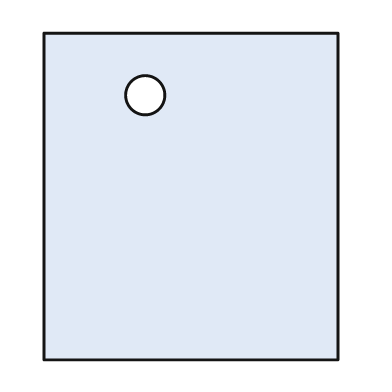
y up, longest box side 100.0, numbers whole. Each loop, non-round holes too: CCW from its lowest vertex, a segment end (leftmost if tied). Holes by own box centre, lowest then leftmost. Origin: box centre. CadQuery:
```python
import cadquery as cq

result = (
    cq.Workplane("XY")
    .moveTo(-45.0, -50.0)
    .lineTo(45.0, -50.0)
    .lineTo(45.0, 50.0)
    .lineTo(-45.0, 50.0)
    .close()
    .moveTo(-14.0, 31.0)
    .circle(6.0)
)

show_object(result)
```